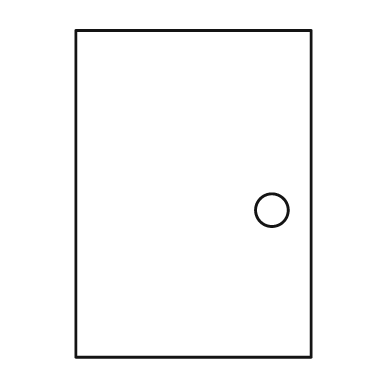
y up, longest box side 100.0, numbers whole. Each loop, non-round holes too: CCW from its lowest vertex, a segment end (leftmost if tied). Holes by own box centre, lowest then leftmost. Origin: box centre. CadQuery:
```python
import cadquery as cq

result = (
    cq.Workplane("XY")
    .moveTo(-36.0, -50.0)
    .lineTo(36.0, -50.0)
    .lineTo(36.0, 50.0)
    .lineTo(-36.0, 50.0)
    .close()
    .moveTo(24.0, -5.0)
    .circle(5.0)
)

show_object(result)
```